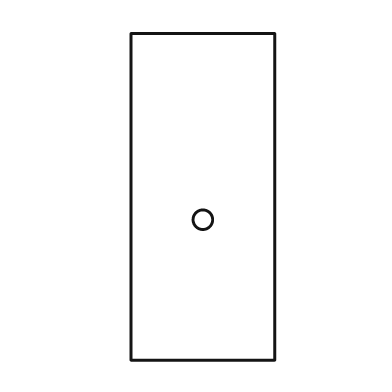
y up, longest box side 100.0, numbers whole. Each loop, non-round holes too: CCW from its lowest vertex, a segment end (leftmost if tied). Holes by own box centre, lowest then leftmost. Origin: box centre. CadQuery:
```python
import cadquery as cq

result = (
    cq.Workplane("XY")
    .moveTo(-22.0, -50.0)
    .lineTo(22.0, -50.0)
    .lineTo(22.0, 50.0)
    .lineTo(-22.0, 50.0)
    .close()
    .moveTo(0.0, -7.0)
    .circle(3.0)
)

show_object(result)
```